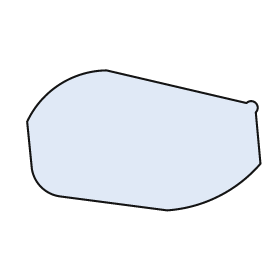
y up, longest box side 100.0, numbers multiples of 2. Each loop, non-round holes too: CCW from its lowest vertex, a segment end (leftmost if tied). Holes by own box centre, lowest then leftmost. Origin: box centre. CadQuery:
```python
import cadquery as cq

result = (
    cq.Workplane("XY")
    .moveTo(10.0, -30.0)
    .threePointArc((32.0, -24.0), (50.0, -10.0))
    .lineTo(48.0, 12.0)
    .threePointArc((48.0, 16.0), (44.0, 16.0))
    .lineTo(-16.0, 30.0)
    .threePointArc((-36.0, 24.0), (-50.0, 8.0))
    .lineTo(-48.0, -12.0)
    .threePointArc((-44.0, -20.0), (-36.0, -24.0))
    .close()
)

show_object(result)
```